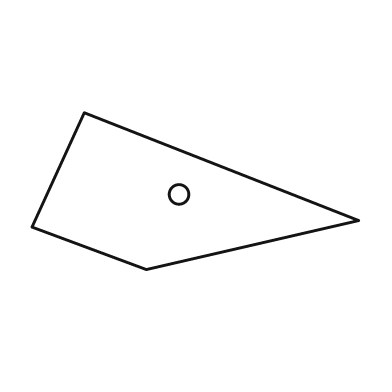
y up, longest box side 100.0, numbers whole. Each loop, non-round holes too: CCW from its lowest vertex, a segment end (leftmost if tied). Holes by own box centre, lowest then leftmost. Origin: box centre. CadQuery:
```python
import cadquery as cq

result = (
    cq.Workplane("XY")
    .moveTo(-15.0, -24.0)
    .lineTo(50.0, -9.0)
    .lineTo(-34.0, 24.0)
    .lineTo(-50.0, -11.0)
    .close()
    .moveTo(-5.0, -1.0)
    .circle(3.0)
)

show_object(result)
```